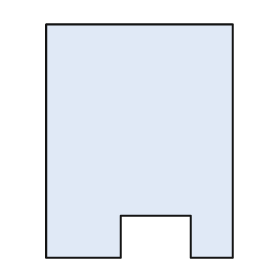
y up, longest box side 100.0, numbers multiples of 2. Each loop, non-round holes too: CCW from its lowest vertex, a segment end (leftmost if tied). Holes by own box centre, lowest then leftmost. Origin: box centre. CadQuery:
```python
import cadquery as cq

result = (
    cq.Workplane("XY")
    .moveTo(-40.0, -50.0)
    .lineTo(-8.0, -50.0)
    .lineTo(-8.0, -32.0)
    .lineTo(22.0, -32.0)
    .lineTo(22.0, -50.0)
    .lineTo(40.0, -50.0)
    .lineTo(40.0, 50.0)
    .lineTo(-40.0, 50.0)
    .close()
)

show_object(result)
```